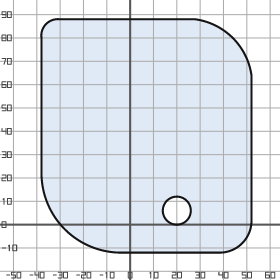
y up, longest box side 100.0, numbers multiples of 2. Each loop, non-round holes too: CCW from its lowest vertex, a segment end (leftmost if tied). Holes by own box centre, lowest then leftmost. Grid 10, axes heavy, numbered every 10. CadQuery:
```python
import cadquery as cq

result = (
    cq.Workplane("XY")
    .moveTo(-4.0, -12.0)
    .lineTo(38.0, -12.0)
    .threePointArc((48.0, -8.0), (52.0, 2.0))
    .lineTo(52.0, 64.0)
    .threePointArc((44.0, 80.0), (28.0, 88.0))
    .lineTo(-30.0, 88.0)
    .threePointArc((-36.0, 86.0), (-38.0, 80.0))
    .lineTo(-38.0, 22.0)
    .threePointArc((-28.0, -2.0), (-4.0, -12.0))
    .close()
    .moveTo(20.0, 6.0)
    .circle(6.0)
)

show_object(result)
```